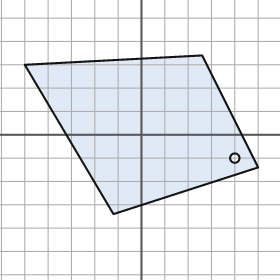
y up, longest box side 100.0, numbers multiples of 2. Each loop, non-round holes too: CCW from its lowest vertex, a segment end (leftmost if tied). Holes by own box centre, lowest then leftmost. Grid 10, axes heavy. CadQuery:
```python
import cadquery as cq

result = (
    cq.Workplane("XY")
    .moveTo(-12.0, -34.0)
    .lineTo(50.0, -14.0)
    .lineTo(26.0, 34.0)
    .lineTo(-50.0, 30.0)
    .close()
    .moveTo(40.0, -10.0)
    .circle(2.0)
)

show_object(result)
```